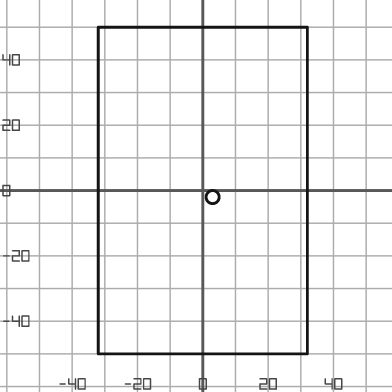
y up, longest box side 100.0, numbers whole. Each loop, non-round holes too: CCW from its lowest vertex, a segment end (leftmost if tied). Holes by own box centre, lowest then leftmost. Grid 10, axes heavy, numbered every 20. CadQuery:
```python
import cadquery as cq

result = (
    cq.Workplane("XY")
    .moveTo(-32.0, -50.0)
    .lineTo(32.0, -50.0)
    .lineTo(32.0, 50.0)
    .lineTo(-32.0, 50.0)
    .close()
    .moveTo(3.0, -2.0)
    .circle(2.0)
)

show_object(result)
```